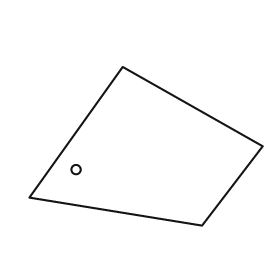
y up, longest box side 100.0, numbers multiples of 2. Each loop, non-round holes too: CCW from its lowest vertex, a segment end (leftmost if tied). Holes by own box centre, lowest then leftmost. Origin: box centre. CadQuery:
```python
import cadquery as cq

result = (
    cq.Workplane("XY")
    .moveTo(24.0, -34.0)
    .lineTo(50.0, 0.0)
    .lineTo(-10.0, 34.0)
    .lineTo(-50.0, -22.0)
    .close()
    .moveTo(-30.0, -10.0)
    .circle(2.0)
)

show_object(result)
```